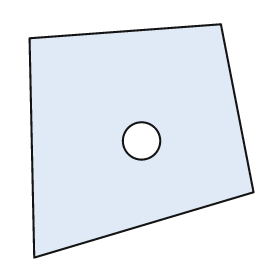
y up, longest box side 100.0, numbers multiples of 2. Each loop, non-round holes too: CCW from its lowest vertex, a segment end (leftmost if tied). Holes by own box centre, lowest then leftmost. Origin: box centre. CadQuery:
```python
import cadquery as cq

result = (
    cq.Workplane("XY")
    .moveTo(-46.0, -50.0)
    .lineTo(48.0, -22.0)
    .lineTo(34.0, 50.0)
    .lineTo(-48.0, 44.0)
    .close()
    .moveTo(0.0, 0.0)
    .circle(8.0)
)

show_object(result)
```